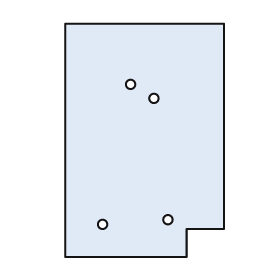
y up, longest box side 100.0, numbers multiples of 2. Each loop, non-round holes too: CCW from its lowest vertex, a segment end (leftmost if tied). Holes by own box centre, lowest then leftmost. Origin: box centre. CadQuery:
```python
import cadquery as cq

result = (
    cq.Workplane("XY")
    .moveTo(-34.0, -50.0)
    .lineTo(18.0, -50.0)
    .lineTo(18.0, -38.0)
    .lineTo(34.0, -38.0)
    .lineTo(34.0, 50.0)
    .lineTo(-34.0, 50.0)
    .close()
    .moveTo(-18.0, -36.0)
    .circle(2.0)
    .moveTo(10.0, -34.0)
    .circle(2.0)
    .moveTo(4.0, 18.0)
    .circle(2.0)
    .moveTo(-6.0, 24.0)
    .circle(2.0)
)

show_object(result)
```